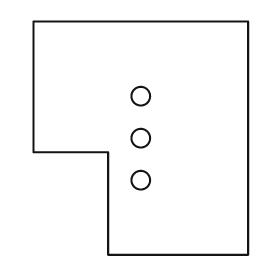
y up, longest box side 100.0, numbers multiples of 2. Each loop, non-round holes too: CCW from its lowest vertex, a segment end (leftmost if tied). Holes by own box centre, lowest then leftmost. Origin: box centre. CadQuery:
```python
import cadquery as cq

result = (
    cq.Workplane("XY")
    .moveTo(-14.0, -50.0)
    .lineTo(46.0, -50.0)
    .lineTo(46.0, 50.0)
    .lineTo(-46.0, 50.0)
    .lineTo(-46.0, -6.0)
    .lineTo(-14.0, -6.0)
    .close()
    .moveTo(0.0, -18.0)
    .circle(4.0)
    .moveTo(0.0, 0.0)
    .circle(4.0)
    .moveTo(0.0, 18.0)
    .circle(4.0)
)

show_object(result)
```